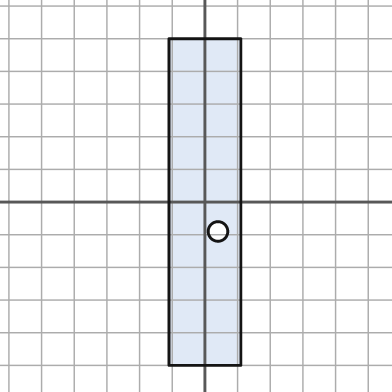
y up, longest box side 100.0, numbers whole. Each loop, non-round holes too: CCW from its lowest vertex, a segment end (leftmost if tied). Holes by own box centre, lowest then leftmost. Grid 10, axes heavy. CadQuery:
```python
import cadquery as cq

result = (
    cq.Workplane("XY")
    .moveTo(-11.0, -50.0)
    .lineTo(11.0, -50.0)
    .lineTo(11.0, 50.0)
    .lineTo(-11.0, 50.0)
    .close()
    .moveTo(4.0, -9.0)
    .circle(3.0)
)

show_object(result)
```